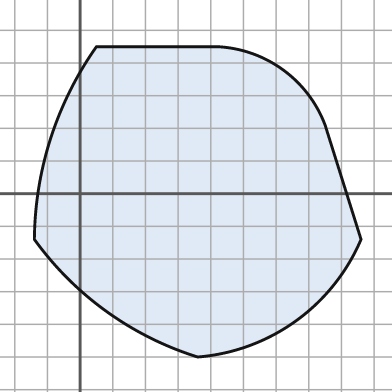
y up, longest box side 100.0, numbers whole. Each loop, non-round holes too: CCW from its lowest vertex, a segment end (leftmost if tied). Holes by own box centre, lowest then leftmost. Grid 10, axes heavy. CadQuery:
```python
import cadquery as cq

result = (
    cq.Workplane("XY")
    .moveTo(36.0, -50.0)
    .threePointArc((66.0, -39.0), (86.0, -14.0))
    .lineTo(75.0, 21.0)
    .threePointArc((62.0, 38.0), (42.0, 45.0))
    .lineTo(5.0, 45.0)
    .threePointArc((-9.0, 17.0), (-14.0, -14.0))
    .threePointArc((8.0, -36.0), (36.0, -50.0))
    .close()
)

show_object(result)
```